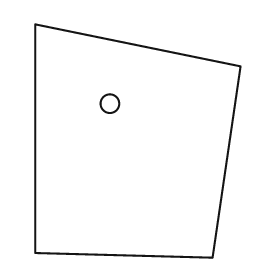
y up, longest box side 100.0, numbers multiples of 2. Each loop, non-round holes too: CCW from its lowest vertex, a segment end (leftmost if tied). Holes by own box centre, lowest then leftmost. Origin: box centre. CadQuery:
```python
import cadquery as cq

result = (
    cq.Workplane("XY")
    .moveTo(32.0, -50.0)
    .lineTo(44.0, 32.0)
    .lineTo(-44.0, 50.0)
    .lineTo(-44.0, -48.0)
    .close()
    .moveTo(-12.0, 16.0)
    .circle(4.0)
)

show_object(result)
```